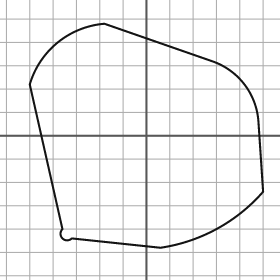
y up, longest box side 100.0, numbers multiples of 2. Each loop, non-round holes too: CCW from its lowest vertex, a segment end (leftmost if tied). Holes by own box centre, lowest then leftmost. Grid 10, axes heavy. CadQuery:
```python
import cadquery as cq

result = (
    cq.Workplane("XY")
    .moveTo(6.0, -48.0)
    .threePointArc((30.0, -40.0), (50.0, -24.0))
    .lineTo(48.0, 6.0)
    .threePointArc((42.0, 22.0), (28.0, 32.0))
    .lineTo(-18.0, 48.0)
    .threePointArc((-38.0, 40.0), (-50.0, 22.0))
    .lineTo(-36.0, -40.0)
    .threePointArc((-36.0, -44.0), (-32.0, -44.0))
    .close()
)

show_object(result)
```